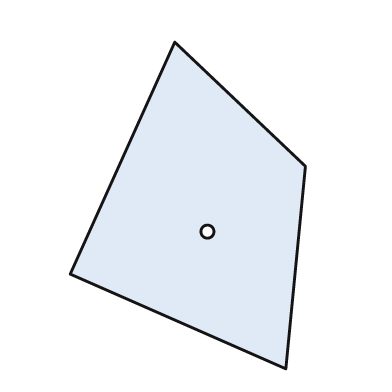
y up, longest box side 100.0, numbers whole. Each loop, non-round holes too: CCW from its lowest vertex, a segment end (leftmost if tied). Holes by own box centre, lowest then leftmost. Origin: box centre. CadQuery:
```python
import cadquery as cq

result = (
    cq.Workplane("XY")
    .moveTo(30.0, -50.0)
    .lineTo(36.0, 12.0)
    .lineTo(-4.0, 50.0)
    .lineTo(-36.0, -21.0)
    .close()
    .moveTo(6.0, -8.0)
    .circle(2.0)
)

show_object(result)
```